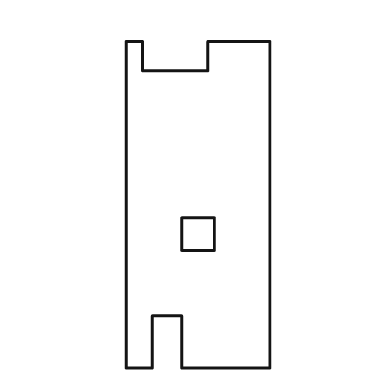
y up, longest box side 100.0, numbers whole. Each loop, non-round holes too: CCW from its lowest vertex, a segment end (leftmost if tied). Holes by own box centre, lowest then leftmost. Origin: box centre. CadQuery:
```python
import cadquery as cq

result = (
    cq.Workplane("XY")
    .moveTo(-22.0, -50.0)
    .lineTo(-14.0, -50.0)
    .lineTo(-14.0, -34.0)
    .lineTo(-5.0, -34.0)
    .lineTo(-5.0, -50.0)
    .lineTo(22.0, -50.0)
    .lineTo(22.0, 50.0)
    .lineTo(3.0, 50.0)
    .lineTo(3.0, 41.0)
    .lineTo(-17.0, 41.0)
    .lineTo(-17.0, 50.0)
    .lineTo(-22.0, 50.0)
    .close()
    .moveTo(-5.0, -14.0)
    .lineTo(5.0, -14.0)
    .lineTo(5.0, -4.0)
    .lineTo(-5.0, -4.0)
    .close()
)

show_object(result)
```